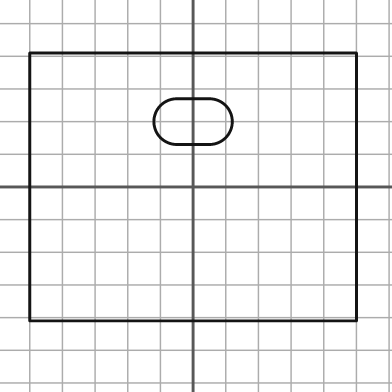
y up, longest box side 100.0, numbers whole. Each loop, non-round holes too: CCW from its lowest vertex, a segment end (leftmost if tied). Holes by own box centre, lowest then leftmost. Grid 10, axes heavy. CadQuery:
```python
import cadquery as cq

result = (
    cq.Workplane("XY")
    .moveTo(-50.0, -41.0)
    .lineTo(50.0, -41.0)
    .lineTo(50.0, 41.0)
    .lineTo(-50.0, 41.0)
    .close()
    .moveTo(-5.0, 13.0)
    .lineTo(5.0, 13.0)
    .threePointArc((12.0, 20.0), (5.0, 27.0))
    .lineTo(-5.0, 27.0)
    .threePointArc((-12.0, 20.0), (-5.0, 13.0))
    .close()
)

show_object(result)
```